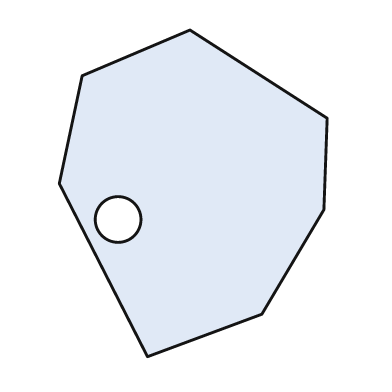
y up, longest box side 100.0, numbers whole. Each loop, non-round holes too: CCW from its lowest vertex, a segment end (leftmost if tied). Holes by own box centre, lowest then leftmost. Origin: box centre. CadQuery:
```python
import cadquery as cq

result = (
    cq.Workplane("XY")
    .moveTo(-14.0, -50.0)
    .lineTo(21.0, -37.0)
    .lineTo(40.0, -5.0)
    .lineTo(41.0, 23.0)
    .lineTo(-1.0, 50.0)
    .lineTo(-34.0, 36.0)
    .lineTo(-41.0, 3.0)
    .close()
    .moveTo(-23.0, -8.0)
    .circle(7.0)
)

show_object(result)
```